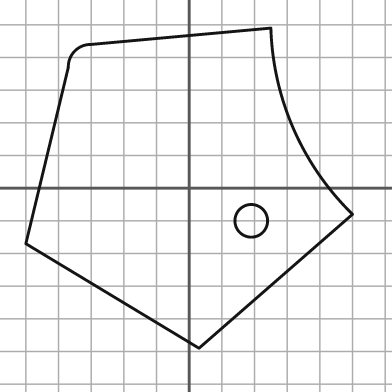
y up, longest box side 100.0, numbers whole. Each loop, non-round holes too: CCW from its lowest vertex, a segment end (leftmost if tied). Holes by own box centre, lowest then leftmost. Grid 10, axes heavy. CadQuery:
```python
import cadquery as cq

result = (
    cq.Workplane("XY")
    .moveTo(3.0, -49.0)
    .lineTo(50.0, -8.0)
    .threePointArc((32.0, 18.0), (25.0, 49.0))
    .lineTo(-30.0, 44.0)
    .threePointArc((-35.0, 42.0), (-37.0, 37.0))
    .lineTo(-50.0, -17.0)
    .close()
    .moveTo(19.0, -10.0)
    .circle(5.0)
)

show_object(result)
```